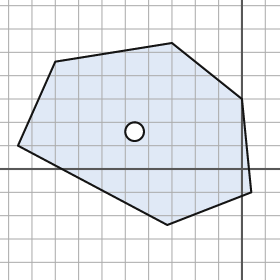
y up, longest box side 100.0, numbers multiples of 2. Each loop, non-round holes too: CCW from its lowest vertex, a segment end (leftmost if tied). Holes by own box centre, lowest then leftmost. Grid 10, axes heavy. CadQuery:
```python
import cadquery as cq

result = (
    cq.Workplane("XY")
    .moveTo(-32.0, -24.0)
    .lineTo(4.0, -10.0)
    .lineTo(0.0, 30.0)
    .lineTo(-30.0, 54.0)
    .lineTo(-80.0, 46.0)
    .lineTo(-96.0, 10.0)
    .close()
    .moveTo(-46.0, 16.0)
    .circle(4.0)
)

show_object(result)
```